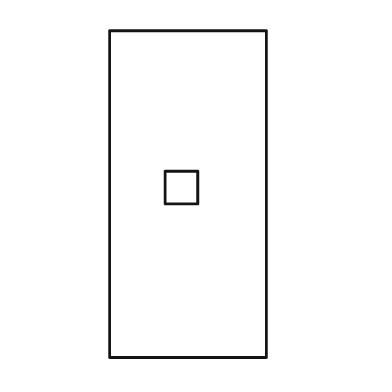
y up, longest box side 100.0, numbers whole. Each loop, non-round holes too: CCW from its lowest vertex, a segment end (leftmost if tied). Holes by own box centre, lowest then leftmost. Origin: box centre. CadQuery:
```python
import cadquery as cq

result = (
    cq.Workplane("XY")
    .moveTo(-24.0, -50.0)
    .lineTo(24.0, -50.0)
    .lineTo(24.0, 50.0)
    .lineTo(-24.0, 50.0)
    .close()
    .moveTo(-7.0, -3.0)
    .lineTo(3.0, -3.0)
    .lineTo(3.0, 7.0)
    .lineTo(-7.0, 7.0)
    .close()
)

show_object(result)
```